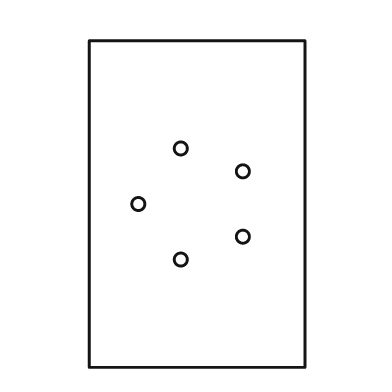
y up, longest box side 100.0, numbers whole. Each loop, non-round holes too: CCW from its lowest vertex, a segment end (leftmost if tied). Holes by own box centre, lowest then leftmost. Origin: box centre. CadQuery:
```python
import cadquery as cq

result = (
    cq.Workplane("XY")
    .moveTo(-33.0, -50.0)
    .lineTo(33.0, -50.0)
    .lineTo(33.0, 50.0)
    .lineTo(-33.0, 50.0)
    .close()
    .moveTo(-5.0, -17.0)
    .circle(2.0)
    .moveTo(14.0, -10.0)
    .circle(2.0)
    .moveTo(-18.0, 0.0)
    .circle(2.0)
    .moveTo(14.0, 10.0)
    .circle(2.0)
    .moveTo(-5.0, 17.0)
    .circle(2.0)
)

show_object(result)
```